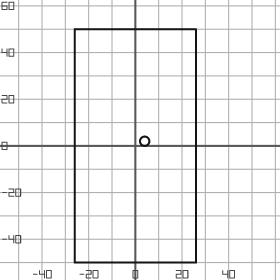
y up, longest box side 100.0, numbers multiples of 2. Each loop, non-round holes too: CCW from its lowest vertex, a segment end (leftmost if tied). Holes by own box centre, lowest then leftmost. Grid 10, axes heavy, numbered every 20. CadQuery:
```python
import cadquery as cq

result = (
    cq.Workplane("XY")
    .moveTo(-26.0, -50.0)
    .lineTo(26.0, -50.0)
    .lineTo(26.0, 50.0)
    .lineTo(-26.0, 50.0)
    .close()
    .moveTo(4.0, 2.0)
    .circle(2.0)
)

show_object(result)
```